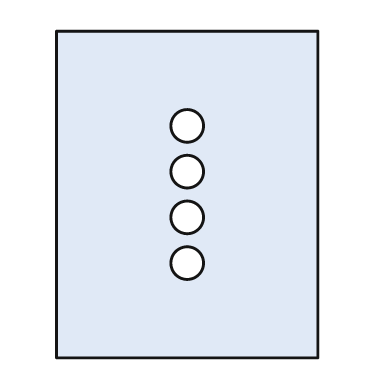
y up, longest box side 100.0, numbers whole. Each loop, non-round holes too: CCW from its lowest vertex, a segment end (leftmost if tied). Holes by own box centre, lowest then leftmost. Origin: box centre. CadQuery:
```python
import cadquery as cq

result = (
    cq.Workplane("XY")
    .moveTo(-40.0, -50.0)
    .lineTo(40.0, -50.0)
    .lineTo(40.0, 50.0)
    .lineTo(-40.0, 50.0)
    .close()
    .moveTo(0.0, -21.0)
    .circle(5.0)
    .moveTo(0.0, -7.0)
    .circle(5.0)
    .moveTo(0.0, 7.0)
    .circle(5.0)
    .moveTo(0.0, 21.0)
    .circle(5.0)
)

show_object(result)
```